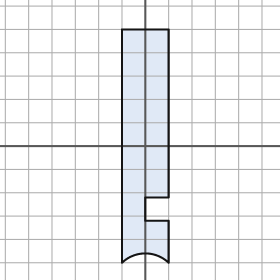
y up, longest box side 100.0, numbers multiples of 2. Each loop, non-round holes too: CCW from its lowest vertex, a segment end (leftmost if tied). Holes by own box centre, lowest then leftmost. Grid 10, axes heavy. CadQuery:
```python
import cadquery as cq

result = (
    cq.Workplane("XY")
    .moveTo(-10.0, -50.0)
    .threePointArc((0.0, -46.0), (10.0, -50.0))
    .lineTo(10.0, -32.0)
    .lineTo(0.0, -32.0)
    .lineTo(0.0, -22.0)
    .lineTo(10.0, -22.0)
    .lineTo(10.0, 50.0)
    .lineTo(-10.0, 50.0)
    .close()
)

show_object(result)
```